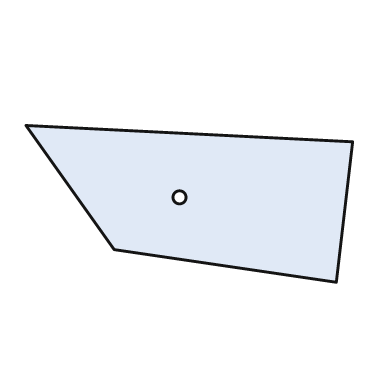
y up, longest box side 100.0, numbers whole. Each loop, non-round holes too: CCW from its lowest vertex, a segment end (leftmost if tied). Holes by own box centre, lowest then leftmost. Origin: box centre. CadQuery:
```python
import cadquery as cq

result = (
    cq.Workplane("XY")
    .moveTo(45.0, -24.0)
    .lineTo(50.0, 19.0)
    .lineTo(-50.0, 24.0)
    .lineTo(-23.0, -14.0)
    .close()
    .moveTo(-3.0, 2.0)
    .circle(2.0)
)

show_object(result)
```